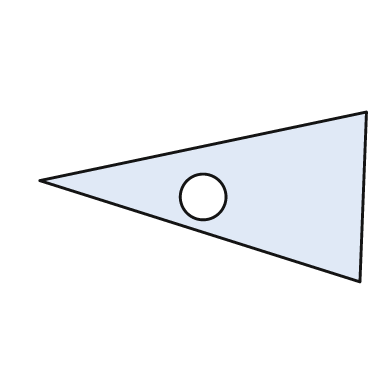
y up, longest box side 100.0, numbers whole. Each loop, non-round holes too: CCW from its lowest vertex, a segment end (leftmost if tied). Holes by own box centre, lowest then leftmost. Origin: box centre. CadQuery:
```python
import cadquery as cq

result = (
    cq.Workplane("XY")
    .moveTo(48.0, -26.0)
    .lineTo(50.0, 26.0)
    .lineTo(-50.0, 5.0)
    .close()
    .moveTo(0.0, 0.0)
    .circle(7.0)
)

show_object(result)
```